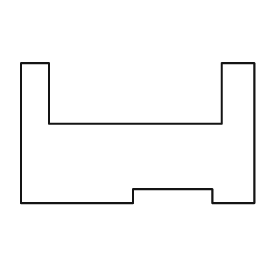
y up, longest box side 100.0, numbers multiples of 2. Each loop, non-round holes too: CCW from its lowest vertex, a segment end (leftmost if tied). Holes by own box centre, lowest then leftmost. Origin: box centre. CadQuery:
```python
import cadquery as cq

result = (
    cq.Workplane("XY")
    .moveTo(-50.0, -30.0)
    .lineTo(-2.0, -30.0)
    .lineTo(-2.0, -24.0)
    .lineTo(32.0, -24.0)
    .lineTo(32.0, -30.0)
    .lineTo(50.0, -30.0)
    .lineTo(50.0, 30.0)
    .lineTo(36.0, 30.0)
    .lineTo(36.0, 4.0)
    .lineTo(-38.0, 4.0)
    .lineTo(-38.0, 30.0)
    .lineTo(-50.0, 30.0)
    .close()
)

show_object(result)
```